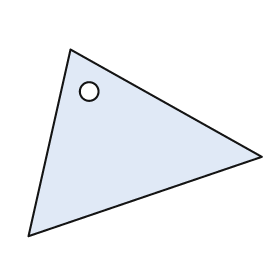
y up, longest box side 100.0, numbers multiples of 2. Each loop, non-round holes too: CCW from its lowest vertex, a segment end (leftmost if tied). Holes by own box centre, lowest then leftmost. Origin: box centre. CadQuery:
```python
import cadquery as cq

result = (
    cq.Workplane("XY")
    .moveTo(-50.0, -40.0)
    .lineTo(50.0, -6.0)
    .lineTo(-32.0, 40.0)
    .close()
    .moveTo(-24.0, 22.0)
    .circle(4.0)
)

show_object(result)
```